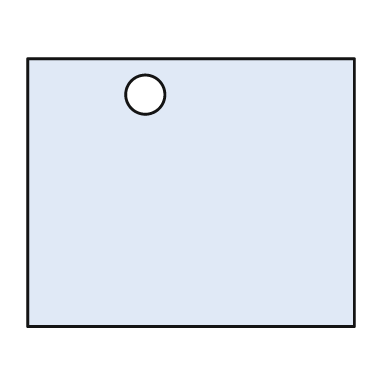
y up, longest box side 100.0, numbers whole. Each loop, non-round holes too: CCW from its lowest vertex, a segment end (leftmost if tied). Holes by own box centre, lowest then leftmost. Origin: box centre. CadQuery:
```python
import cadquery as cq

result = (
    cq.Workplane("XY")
    .moveTo(-50.0, -41.0)
    .lineTo(50.0, -41.0)
    .lineTo(50.0, 41.0)
    .lineTo(-50.0, 41.0)
    .close()
    .moveTo(-14.0, 30.0)
    .circle(6.0)
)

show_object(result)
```